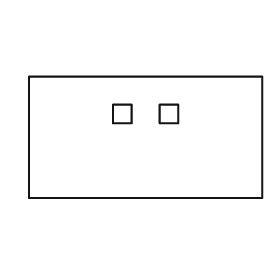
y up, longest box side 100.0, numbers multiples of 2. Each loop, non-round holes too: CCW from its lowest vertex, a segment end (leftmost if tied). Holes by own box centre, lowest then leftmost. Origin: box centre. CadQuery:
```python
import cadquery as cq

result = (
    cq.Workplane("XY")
    .moveTo(-50.0, -26.0)
    .lineTo(50.0, -26.0)
    .lineTo(50.0, 26.0)
    .lineTo(-50.0, 26.0)
    .close()
    .moveTo(-14.0, 6.0)
    .lineTo(-6.0, 6.0)
    .lineTo(-6.0, 14.0)
    .lineTo(-14.0, 14.0)
    .close()
    .moveTo(6.0, 6.0)
    .lineTo(14.0, 6.0)
    .lineTo(14.0, 14.0)
    .lineTo(6.0, 14.0)
    .close()
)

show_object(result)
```